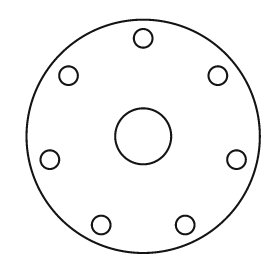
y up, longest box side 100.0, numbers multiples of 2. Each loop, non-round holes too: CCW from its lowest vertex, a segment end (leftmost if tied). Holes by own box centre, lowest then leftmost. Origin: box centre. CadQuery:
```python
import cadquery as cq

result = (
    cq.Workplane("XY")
    .moveTo(0.0, 0.0)
    .circle(50.0)
    .moveTo(-18.0, -38.0)
    .circle(4.0)
    .moveTo(18.0, -38.0)
    .circle(4.0)
    .moveTo(-40.0, -10.0)
    .circle(4.0)
    .moveTo(40.0, -10.0)
    .circle(4.0)
    .moveTo(0.0, 0.0)
    .circle(12.0)
    .moveTo(-32.0, 26.0)
    .circle(4.0)
    .moveTo(32.0, 26.0)
    .circle(4.0)
    .moveTo(0.0, 42.0)
    .circle(4.0)
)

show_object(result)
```